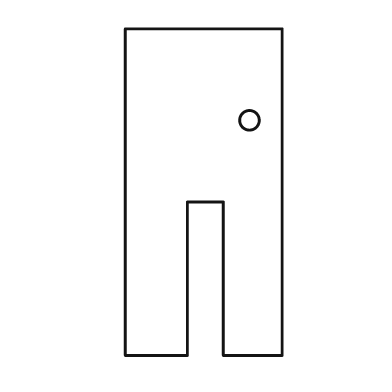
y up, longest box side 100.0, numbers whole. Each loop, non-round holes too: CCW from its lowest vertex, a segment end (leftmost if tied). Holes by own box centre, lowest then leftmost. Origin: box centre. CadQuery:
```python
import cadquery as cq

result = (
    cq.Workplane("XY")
    .moveTo(-24.0, -50.0)
    .lineTo(-5.0, -50.0)
    .lineTo(-5.0, -3.0)
    .lineTo(6.0, -3.0)
    .lineTo(6.0, -50.0)
    .lineTo(24.0, -50.0)
    .lineTo(24.0, 50.0)
    .lineTo(-24.0, 50.0)
    .close()
    .moveTo(14.0, 22.0)
    .circle(3.0)
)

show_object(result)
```